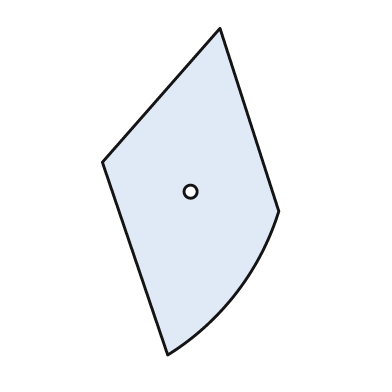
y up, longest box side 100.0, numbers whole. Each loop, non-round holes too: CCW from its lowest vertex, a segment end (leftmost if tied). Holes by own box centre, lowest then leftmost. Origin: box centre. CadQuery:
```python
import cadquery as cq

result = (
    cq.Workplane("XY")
    .moveTo(-7.0, -50.0)
    .threePointArc((14.0, -31.0), (27.0, -6.0))
    .lineTo(9.0, 50.0)
    .lineTo(-27.0, 9.0)
    .close()
    .moveTo(0.0, 0.0)
    .circle(2.0)
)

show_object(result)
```